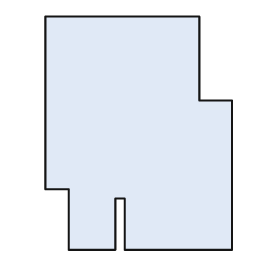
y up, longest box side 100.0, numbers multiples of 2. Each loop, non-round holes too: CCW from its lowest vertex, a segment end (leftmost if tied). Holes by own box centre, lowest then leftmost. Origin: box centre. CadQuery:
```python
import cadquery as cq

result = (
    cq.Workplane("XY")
    .moveTo(-30.0, -50.0)
    .lineTo(-10.0, -50.0)
    .lineTo(-10.0, -28.0)
    .lineTo(-6.0, -28.0)
    .lineTo(-6.0, -50.0)
    .lineTo(40.0, -50.0)
    .lineTo(40.0, 14.0)
    .lineTo(26.0, 14.0)
    .lineTo(26.0, 50.0)
    .lineTo(-40.0, 50.0)
    .lineTo(-40.0, -24.0)
    .lineTo(-30.0, -24.0)
    .close()
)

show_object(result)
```